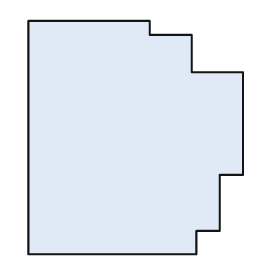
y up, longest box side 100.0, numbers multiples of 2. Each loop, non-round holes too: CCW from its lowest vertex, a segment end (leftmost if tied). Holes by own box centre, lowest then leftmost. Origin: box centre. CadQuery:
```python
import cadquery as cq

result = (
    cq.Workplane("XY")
    .moveTo(-46.0, -50.0)
    .lineTo(26.0, -50.0)
    .lineTo(26.0, -40.0)
    .lineTo(36.0, -40.0)
    .lineTo(36.0, -16.0)
    .lineTo(46.0, -16.0)
    .lineTo(46.0, 28.0)
    .lineTo(24.0, 28.0)
    .lineTo(24.0, 44.0)
    .lineTo(6.0, 44.0)
    .lineTo(6.0, 50.0)
    .lineTo(-46.0, 50.0)
    .close()
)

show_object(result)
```